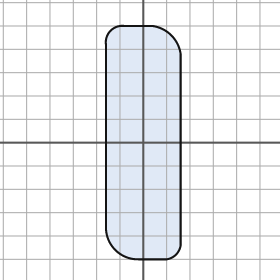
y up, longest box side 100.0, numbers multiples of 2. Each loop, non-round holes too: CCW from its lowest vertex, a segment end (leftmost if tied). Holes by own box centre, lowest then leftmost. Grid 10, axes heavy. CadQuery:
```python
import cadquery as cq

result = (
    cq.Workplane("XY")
    .moveTo(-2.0, -50.0)
    .lineTo(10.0, -50.0)
    .threePointArc((14.0, -48.0), (16.0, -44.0))
    .lineTo(16.0, 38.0)
    .threePointArc((12.0, 46.0), (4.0, 50.0))
    .lineTo(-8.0, 50.0)
    .threePointArc((-14.0, 48.0), (-16.0, 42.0))
    .lineTo(-16.0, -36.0)
    .threePointArc((-12.0, -46.0), (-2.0, -50.0))
    .close()
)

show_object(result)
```